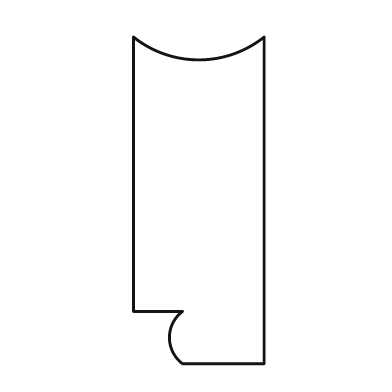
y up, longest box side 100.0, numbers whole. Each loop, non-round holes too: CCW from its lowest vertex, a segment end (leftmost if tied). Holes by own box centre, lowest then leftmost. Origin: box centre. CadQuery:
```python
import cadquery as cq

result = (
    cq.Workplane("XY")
    .moveTo(-5.0, -50.0)
    .lineTo(20.0, -50.0)
    .lineTo(20.0, 50.0)
    .threePointArc((0.0, 43.0), (-20.0, 50.0))
    .lineTo(-20.0, -34.0)
    .lineTo(-5.0, -34.0)
    .threePointArc((-9.0, -42.0), (-5.0, -50.0))
    .close()
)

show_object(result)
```